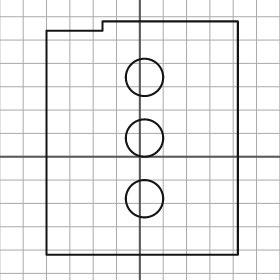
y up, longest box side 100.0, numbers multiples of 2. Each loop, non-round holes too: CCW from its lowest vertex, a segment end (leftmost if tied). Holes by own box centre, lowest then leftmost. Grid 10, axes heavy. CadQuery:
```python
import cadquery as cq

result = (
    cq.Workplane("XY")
    .moveTo(-40.0, -42.0)
    .lineTo(42.0, -42.0)
    .lineTo(42.0, 58.0)
    .lineTo(-16.0, 58.0)
    .lineTo(-16.0, 54.0)
    .lineTo(-40.0, 54.0)
    .close()
    .moveTo(2.0, -18.0)
    .circle(8.0)
    .moveTo(2.0, 8.0)
    .circle(8.0)
    .moveTo(2.0, 34.0)
    .circle(8.0)
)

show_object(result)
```